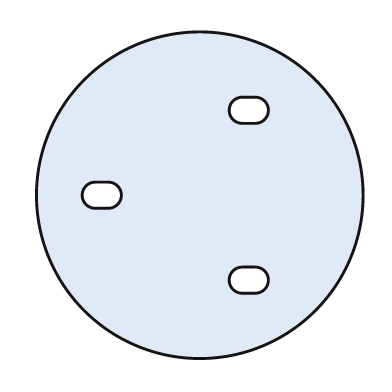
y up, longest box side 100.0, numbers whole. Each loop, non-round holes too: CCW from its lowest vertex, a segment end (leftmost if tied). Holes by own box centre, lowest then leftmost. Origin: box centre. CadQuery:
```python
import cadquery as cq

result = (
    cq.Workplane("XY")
    .moveTo(0.0, 0.0)
    .circle(50.0)
    .moveTo(13.0, -30.0)
    .lineTo(17.0, -30.0)
    .threePointArc((21.0, -26.0), (17.0, -22.0))
    .lineTo(13.0, -22.0)
    .threePointArc((9.0, -26.0), (13.0, -30.0))
    .close()
    .moveTo(-32.0, -4.0)
    .lineTo(-28.0, -4.0)
    .threePointArc((-24.0, 0.0), (-28.0, 4.0))
    .lineTo(-32.0, 4.0)
    .threePointArc((-36.0, 0.0), (-32.0, -4.0))
    .close()
    .moveTo(13.0, 22.0)
    .lineTo(17.0, 22.0)
    .threePointArc((21.0, 26.0), (17.0, 30.0))
    .lineTo(13.0, 30.0)
    .threePointArc((9.0, 26.0), (13.0, 22.0))
    .close()
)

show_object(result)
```